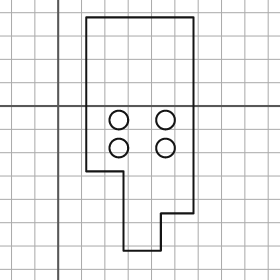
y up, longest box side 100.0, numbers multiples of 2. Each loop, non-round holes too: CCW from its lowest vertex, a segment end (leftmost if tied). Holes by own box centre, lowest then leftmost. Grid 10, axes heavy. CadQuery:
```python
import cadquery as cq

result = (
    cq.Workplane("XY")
    .moveTo(28.0, -62.0)
    .lineTo(44.0, -62.0)
    .lineTo(44.0, -46.0)
    .lineTo(58.0, -46.0)
    .lineTo(58.0, 38.0)
    .lineTo(12.0, 38.0)
    .lineTo(12.0, -28.0)
    .lineTo(28.0, -28.0)
    .close()
    .moveTo(26.0, -18.0)
    .circle(4.0)
    .moveTo(46.0, -18.0)
    .circle(4.0)
    .moveTo(26.0, -6.0)
    .circle(4.0)
    .moveTo(46.0, -6.0)
    .circle(4.0)
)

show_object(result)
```